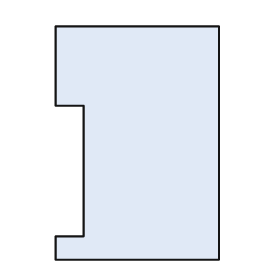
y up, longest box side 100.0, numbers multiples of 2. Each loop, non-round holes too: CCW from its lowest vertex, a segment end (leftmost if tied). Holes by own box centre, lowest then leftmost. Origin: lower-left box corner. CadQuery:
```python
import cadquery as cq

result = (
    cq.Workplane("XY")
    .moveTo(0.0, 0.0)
    .lineTo(70.0, 0.0)
    .lineTo(70.0, 100.0)
    .lineTo(0.0, 100.0)
    .lineTo(0.0, 66.0)
    .lineTo(12.0, 66.0)
    .lineTo(12.0, 10.0)
    .lineTo(0.0, 10.0)
    .close()
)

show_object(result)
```